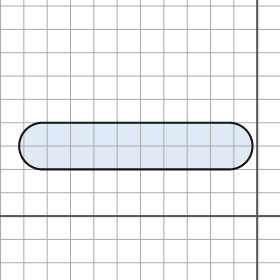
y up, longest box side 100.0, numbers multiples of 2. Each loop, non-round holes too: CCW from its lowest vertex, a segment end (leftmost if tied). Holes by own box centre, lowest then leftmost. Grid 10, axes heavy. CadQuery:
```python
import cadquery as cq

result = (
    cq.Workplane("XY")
    .moveTo(-92.0, 20.0)
    .lineTo(-12.0, 20.0)
    .threePointArc((-2.0, 30.0), (-12.0, 40.0))
    .lineTo(-92.0, 40.0)
    .threePointArc((-102.0, 30.0), (-92.0, 20.0))
    .close()
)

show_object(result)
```